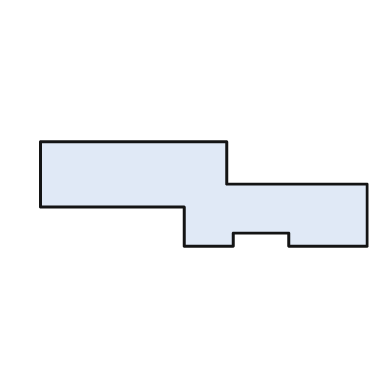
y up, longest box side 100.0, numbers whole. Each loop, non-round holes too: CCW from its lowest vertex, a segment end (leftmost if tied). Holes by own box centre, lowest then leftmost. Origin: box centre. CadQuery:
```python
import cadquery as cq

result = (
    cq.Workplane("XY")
    .moveTo(-6.0, -16.0)
    .lineTo(9.0, -16.0)
    .lineTo(9.0, -12.0)
    .lineTo(26.0, -12.0)
    .lineTo(26.0, -16.0)
    .lineTo(50.0, -16.0)
    .lineTo(50.0, 3.0)
    .lineTo(7.0, 3.0)
    .lineTo(7.0, 16.0)
    .lineTo(-50.0, 16.0)
    .lineTo(-50.0, -4.0)
    .lineTo(-6.0, -4.0)
    .close()
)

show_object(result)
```